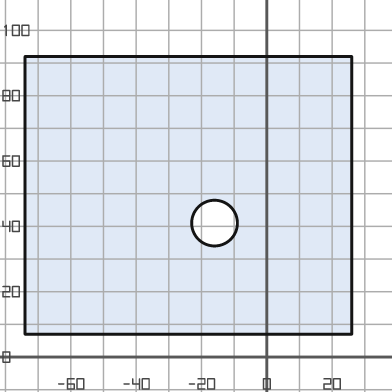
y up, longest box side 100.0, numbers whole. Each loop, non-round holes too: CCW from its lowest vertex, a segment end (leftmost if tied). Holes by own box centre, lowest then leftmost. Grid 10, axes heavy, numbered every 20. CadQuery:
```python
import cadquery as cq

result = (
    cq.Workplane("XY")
    .moveTo(-74.0, 7.0)
    .lineTo(26.0, 7.0)
    .lineTo(26.0, 92.0)
    .lineTo(-74.0, 92.0)
    .close()
    .moveTo(-16.0, 41.0)
    .circle(7.0)
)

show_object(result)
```